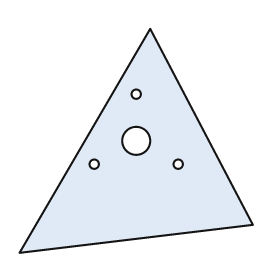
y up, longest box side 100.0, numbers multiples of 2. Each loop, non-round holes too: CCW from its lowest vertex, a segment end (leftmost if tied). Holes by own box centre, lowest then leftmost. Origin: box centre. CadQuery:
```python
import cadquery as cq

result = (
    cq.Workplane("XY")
    .moveTo(-50.0, -48.0)
    .lineTo(50.0, -36.0)
    .lineTo(6.0, 48.0)
    .close()
    .moveTo(-18.0, -10.0)
    .circle(2.0)
    .moveTo(18.0, -10.0)
    .circle(2.0)
    .moveTo(0.0, 0.0)
    .circle(6.0)
    .moveTo(0.0, 20.0)
    .circle(2.0)
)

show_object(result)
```